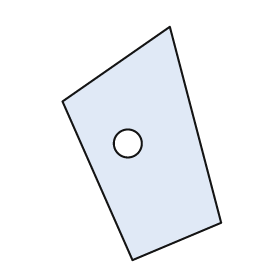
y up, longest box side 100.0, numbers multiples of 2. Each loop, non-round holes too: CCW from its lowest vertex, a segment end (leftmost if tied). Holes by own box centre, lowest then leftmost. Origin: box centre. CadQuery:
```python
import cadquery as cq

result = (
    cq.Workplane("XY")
    .moveTo(-4.0, -50.0)
    .lineTo(34.0, -34.0)
    .lineTo(12.0, 50.0)
    .lineTo(-34.0, 18.0)
    .close()
    .moveTo(-6.0, 0.0)
    .circle(6.0)
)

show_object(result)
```